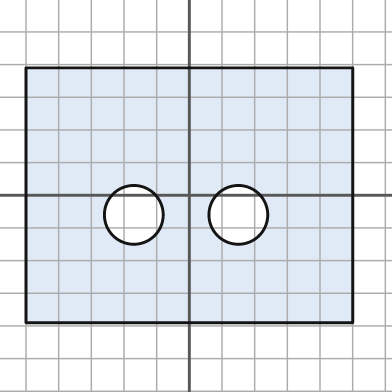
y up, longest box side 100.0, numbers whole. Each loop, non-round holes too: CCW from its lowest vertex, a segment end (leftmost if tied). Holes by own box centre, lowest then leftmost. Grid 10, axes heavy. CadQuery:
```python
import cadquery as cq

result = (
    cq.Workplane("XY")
    .moveTo(-50.0, -39.0)
    .lineTo(50.0, -39.0)
    .lineTo(50.0, 39.0)
    .lineTo(-50.0, 39.0)
    .close()
    .moveTo(-17.0, -6.0)
    .circle(9.0)
    .moveTo(15.0, -6.0)
    .circle(9.0)
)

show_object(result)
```